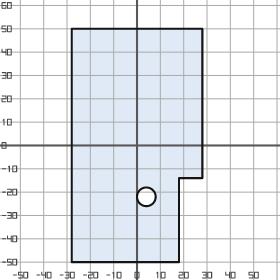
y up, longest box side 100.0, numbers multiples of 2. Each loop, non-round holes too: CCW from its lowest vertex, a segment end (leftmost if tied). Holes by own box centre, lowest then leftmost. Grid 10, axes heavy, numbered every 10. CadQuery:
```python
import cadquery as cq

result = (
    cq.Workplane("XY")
    .moveTo(-28.0, -50.0)
    .lineTo(18.0, -50.0)
    .lineTo(18.0, -14.0)
    .lineTo(28.0, -14.0)
    .lineTo(28.0, 50.0)
    .lineTo(-28.0, 50.0)
    .close()
    .moveTo(4.0, -22.0)
    .circle(4.0)
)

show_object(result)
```